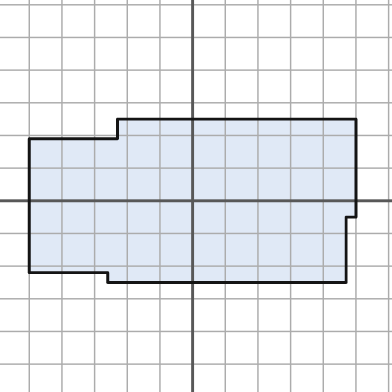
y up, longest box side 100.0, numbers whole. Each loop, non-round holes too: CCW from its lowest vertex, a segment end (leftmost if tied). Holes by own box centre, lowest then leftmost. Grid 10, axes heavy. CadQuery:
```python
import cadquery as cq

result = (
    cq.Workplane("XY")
    .moveTo(-26.0, -25.0)
    .lineTo(47.0, -25.0)
    .lineTo(47.0, -5.0)
    .lineTo(50.0, -5.0)
    .lineTo(50.0, 25.0)
    .lineTo(-23.0, 25.0)
    .lineTo(-23.0, 19.0)
    .lineTo(-50.0, 19.0)
    .lineTo(-50.0, -22.0)
    .lineTo(-26.0, -22.0)
    .close()
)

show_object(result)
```